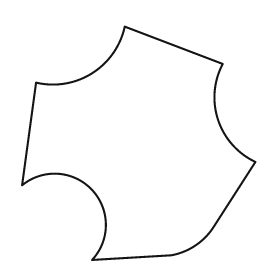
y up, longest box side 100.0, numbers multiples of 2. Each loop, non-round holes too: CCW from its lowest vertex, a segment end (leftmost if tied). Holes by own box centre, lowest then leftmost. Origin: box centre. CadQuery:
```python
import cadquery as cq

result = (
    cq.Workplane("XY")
    .moveTo(-20.0, -50.0)
    .lineTo(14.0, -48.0)
    .threePointArc((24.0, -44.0), (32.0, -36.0))
    .lineTo(50.0, -8.0)
    .threePointArc((34.0, 10.0), (36.0, 34.0))
    .lineTo(-6.0, 50.0)
    .threePointArc((-20.0, 30.0), (-44.0, 26.0))
    .lineTo(-50.0, -18.0)
    .threePointArc((-20.0, -20.0), (-20.0, -50.0))
    .close()
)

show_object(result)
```